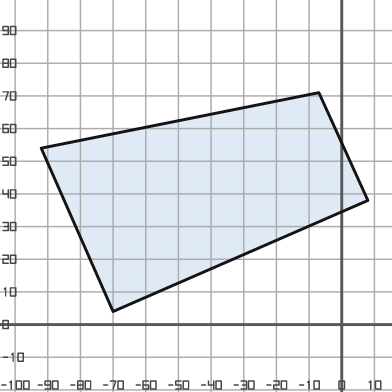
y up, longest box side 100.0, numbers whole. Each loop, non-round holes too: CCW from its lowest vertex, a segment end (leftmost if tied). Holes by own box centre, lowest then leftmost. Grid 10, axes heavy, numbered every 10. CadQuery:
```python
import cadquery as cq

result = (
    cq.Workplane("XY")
    .moveTo(-70.0, 4.0)
    .lineTo(8.0, 38.0)
    .lineTo(-7.0, 71.0)
    .lineTo(-92.0, 54.0)
    .close()
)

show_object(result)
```